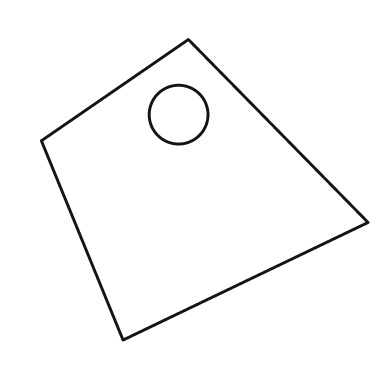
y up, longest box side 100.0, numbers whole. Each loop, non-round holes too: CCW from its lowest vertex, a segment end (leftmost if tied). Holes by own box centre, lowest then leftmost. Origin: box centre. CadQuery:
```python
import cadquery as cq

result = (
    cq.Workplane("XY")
    .moveTo(-25.0, -46.0)
    .lineTo(50.0, -10.0)
    .lineTo(-5.0, 46.0)
    .lineTo(-50.0, 15.0)
    .close()
    .moveTo(-8.0, 23.0)
    .circle(9.0)
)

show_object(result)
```